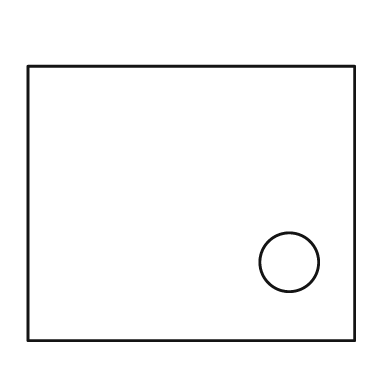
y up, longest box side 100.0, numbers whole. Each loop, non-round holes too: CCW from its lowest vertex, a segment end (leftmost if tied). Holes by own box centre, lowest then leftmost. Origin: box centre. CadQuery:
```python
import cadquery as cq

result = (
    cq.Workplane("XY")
    .moveTo(-50.0, -42.0)
    .lineTo(50.0, -42.0)
    .lineTo(50.0, 42.0)
    .lineTo(-50.0, 42.0)
    .close()
    .moveTo(30.0, -18.0)
    .circle(9.0)
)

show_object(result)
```